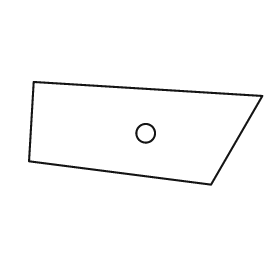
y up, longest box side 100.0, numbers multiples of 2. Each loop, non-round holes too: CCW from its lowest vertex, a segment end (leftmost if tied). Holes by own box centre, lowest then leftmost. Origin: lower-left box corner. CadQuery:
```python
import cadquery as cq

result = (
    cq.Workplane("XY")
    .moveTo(78.0, 0.0)
    .lineTo(100.0, 38.0)
    .lineTo(2.0, 44.0)
    .lineTo(0.0, 10.0)
    .close()
    .moveTo(50.0, 22.0)
    .circle(4.0)
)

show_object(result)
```